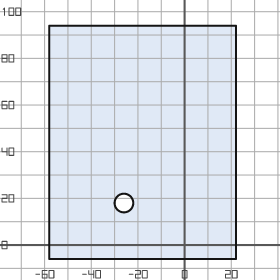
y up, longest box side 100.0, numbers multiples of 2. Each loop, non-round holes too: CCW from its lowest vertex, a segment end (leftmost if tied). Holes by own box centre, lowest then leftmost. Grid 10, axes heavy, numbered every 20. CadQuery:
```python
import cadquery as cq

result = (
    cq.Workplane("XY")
    .moveTo(-58.0, -6.0)
    .lineTo(22.0, -6.0)
    .lineTo(22.0, 94.0)
    .lineTo(-58.0, 94.0)
    .close()
    .moveTo(-26.0, 18.0)
    .circle(4.0)
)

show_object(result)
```